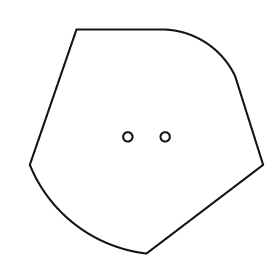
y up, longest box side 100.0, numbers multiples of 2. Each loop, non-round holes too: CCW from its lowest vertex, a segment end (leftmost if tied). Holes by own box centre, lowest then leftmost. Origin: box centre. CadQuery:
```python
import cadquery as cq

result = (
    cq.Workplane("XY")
    .moveTo(0.0, -48.0)
    .lineTo(50.0, -10.0)
    .lineTo(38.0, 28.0)
    .threePointArc((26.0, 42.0), (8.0, 48.0))
    .lineTo(-30.0, 48.0)
    .lineTo(-50.0, -10.0)
    .threePointArc((-30.0, -36.0), (0.0, -48.0))
    .close()
    .moveTo(-8.0, 2.0)
    .circle(2.0)
    .moveTo(8.0, 2.0)
    .circle(2.0)
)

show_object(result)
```